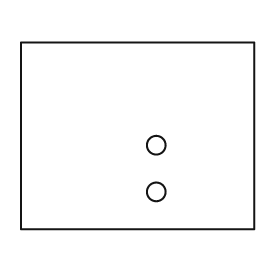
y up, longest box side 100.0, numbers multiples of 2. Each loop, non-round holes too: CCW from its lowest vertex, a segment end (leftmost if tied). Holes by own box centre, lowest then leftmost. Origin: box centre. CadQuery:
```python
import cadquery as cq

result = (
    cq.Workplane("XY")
    .moveTo(-50.0, -40.0)
    .lineTo(50.0, -40.0)
    .lineTo(50.0, 40.0)
    .lineTo(-50.0, 40.0)
    .close()
    .moveTo(8.0, -24.0)
    .circle(4.0)
    .moveTo(8.0, -4.0)
    .circle(4.0)
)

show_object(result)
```